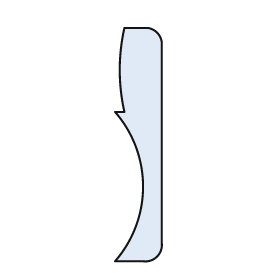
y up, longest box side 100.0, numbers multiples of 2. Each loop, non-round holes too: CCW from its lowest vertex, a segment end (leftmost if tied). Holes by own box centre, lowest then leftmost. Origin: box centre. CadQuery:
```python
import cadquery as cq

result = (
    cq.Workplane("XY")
    .moveTo(-10.0, -50.0)
    .lineTo(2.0, -50.0)
    .threePointArc((8.0, -48.0), (10.0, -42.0))
    .lineTo(10.0, 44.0)
    .threePointArc((8.0, 48.0), (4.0, 50.0))
    .lineTo(-6.0, 50.0)
    .threePointArc((-8.0, 32.0), (-6.0, 14.0))
    .lineTo(-10.0, 14.0)
    .threePointArc((2.0, -18.0), (-10.0, -50.0))
    .close()
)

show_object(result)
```